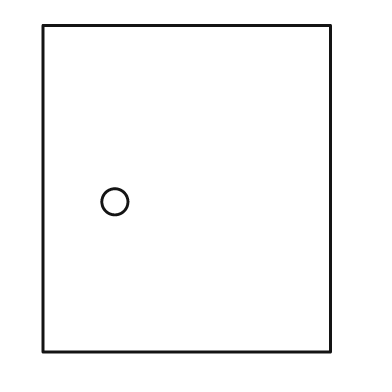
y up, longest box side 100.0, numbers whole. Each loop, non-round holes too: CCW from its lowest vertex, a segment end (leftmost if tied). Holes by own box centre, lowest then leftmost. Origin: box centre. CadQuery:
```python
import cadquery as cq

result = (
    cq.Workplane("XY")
    .moveTo(-44.0, -50.0)
    .lineTo(44.0, -50.0)
    .lineTo(44.0, 50.0)
    .lineTo(-44.0, 50.0)
    .close()
    .moveTo(-22.0, -4.0)
    .circle(4.0)
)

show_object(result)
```